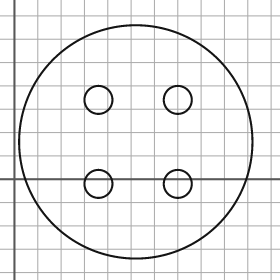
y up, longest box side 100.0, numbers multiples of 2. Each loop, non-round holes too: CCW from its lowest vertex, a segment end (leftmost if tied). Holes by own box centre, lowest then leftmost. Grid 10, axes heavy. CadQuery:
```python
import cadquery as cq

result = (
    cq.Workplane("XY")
    .moveTo(52.0, 16.0)
    .circle(50.0)
    .moveTo(36.0, -2.0)
    .circle(6.0)
    .moveTo(70.0, -2.0)
    .circle(6.0)
    .moveTo(36.0, 34.0)
    .circle(6.0)
    .moveTo(70.0, 34.0)
    .circle(6.0)
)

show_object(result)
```